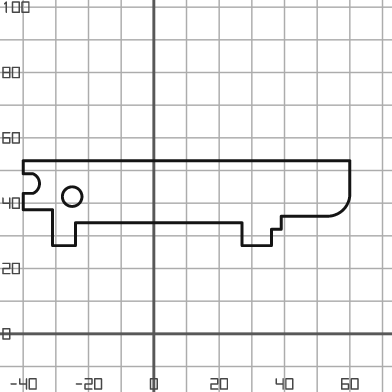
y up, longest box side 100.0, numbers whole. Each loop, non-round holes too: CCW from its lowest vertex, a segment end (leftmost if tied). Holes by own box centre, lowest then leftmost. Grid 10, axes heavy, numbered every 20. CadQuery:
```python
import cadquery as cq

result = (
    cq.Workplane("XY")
    .moveTo(-31.0, 27.0)
    .lineTo(-24.0, 27.0)
    .lineTo(-24.0, 34.0)
    .lineTo(27.0, 34.0)
    .lineTo(27.0, 27.0)
    .lineTo(36.0, 27.0)
    .lineTo(36.0, 32.0)
    .lineTo(39.0, 32.0)
    .lineTo(39.0, 36.0)
    .lineTo(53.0, 36.0)
    .threePointArc((58.0, 38.0), (60.0, 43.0))
    .lineTo(60.0, 53.0)
    .lineTo(-40.0, 53.0)
    .lineTo(-40.0, 49.0)
    .lineTo(-37.0, 49.0)
    .threePointArc((-35.0, 46.0), (-37.0, 43.0))
    .lineTo(-40.0, 43.0)
    .lineTo(-40.0, 38.0)
    .lineTo(-31.0, 38.0)
    .close()
    .moveTo(-25.0, 42.0)
    .circle(3.0)
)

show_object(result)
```